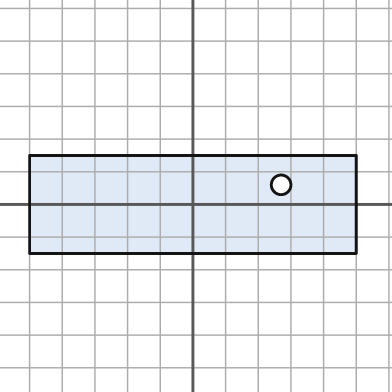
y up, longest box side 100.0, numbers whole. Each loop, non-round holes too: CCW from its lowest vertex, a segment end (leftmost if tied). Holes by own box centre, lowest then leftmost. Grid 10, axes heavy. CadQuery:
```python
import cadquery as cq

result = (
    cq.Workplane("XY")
    .moveTo(-50.0, -15.0)
    .lineTo(50.0, -15.0)
    .lineTo(50.0, 15.0)
    .lineTo(-50.0, 15.0)
    .close()
    .moveTo(27.0, 6.0)
    .circle(3.0)
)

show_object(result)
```